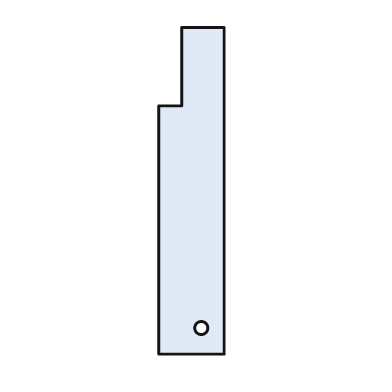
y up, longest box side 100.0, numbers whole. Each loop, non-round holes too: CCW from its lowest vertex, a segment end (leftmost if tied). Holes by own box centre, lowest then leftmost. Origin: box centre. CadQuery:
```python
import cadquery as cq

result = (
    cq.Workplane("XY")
    .moveTo(-10.0, -50.0)
    .lineTo(10.0, -50.0)
    .lineTo(10.0, 50.0)
    .lineTo(-3.0, 50.0)
    .lineTo(-3.0, 26.0)
    .lineTo(-10.0, 26.0)
    .close()
    .moveTo(3.0, -42.0)
    .circle(2.0)
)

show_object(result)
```